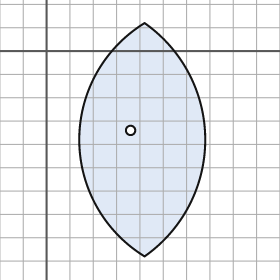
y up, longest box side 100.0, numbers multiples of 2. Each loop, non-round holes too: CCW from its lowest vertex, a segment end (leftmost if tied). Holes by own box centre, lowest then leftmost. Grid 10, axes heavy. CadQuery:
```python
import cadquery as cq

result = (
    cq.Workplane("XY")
    .moveTo(42.0, -88.0)
    .threePointArc((68.0, -38.0), (42.0, 12.0))
    .threePointArc((14.0, -38.0), (42.0, -88.0))
    .close()
    .moveTo(36.0, -34.0)
    .circle(2.0)
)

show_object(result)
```